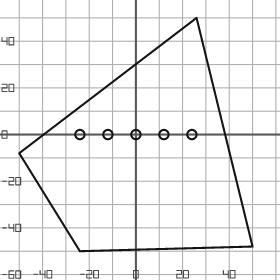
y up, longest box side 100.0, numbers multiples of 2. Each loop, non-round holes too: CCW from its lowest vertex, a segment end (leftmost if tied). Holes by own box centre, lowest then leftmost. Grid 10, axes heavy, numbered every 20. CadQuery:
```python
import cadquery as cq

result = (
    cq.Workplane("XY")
    .moveTo(-24.0, -50.0)
    .lineTo(50.0, -48.0)
    .lineTo(26.0, 50.0)
    .lineTo(-50.0, -8.0)
    .close()
    .moveTo(-24.0, 0.0)
    .circle(2.0)
    .moveTo(-12.0, 0.0)
    .circle(2.0)
    .moveTo(0.0, 0.0)
    .circle(2.0)
    .moveTo(12.0, 0.0)
    .circle(2.0)
    .moveTo(24.0, 0.0)
    .circle(2.0)
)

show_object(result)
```